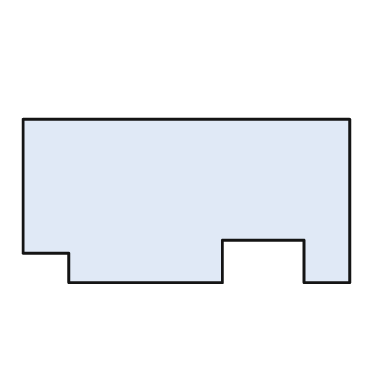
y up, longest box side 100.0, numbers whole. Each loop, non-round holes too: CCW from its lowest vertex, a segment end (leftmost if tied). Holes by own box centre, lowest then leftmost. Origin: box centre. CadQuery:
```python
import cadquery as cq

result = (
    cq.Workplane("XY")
    .moveTo(-36.0, -25.0)
    .lineTo(11.0, -25.0)
    .lineTo(11.0, -12.0)
    .lineTo(36.0, -12.0)
    .lineTo(36.0, -25.0)
    .lineTo(50.0, -25.0)
    .lineTo(50.0, 25.0)
    .lineTo(-50.0, 25.0)
    .lineTo(-50.0, -16.0)
    .lineTo(-36.0, -16.0)
    .close()
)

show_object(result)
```